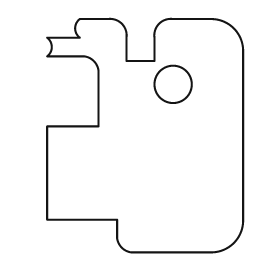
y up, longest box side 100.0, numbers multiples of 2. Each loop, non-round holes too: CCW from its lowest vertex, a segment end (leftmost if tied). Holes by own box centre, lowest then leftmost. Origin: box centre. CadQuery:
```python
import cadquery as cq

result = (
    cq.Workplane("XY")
    .moveTo(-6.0, -50.0)
    .lineTo(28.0, -50.0)
    .threePointArc((38.0, -46.0), (42.0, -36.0))
    .lineTo(42.0, 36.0)
    .threePointArc((38.0, 46.0), (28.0, 50.0))
    .lineTo(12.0, 50.0)
    .threePointArc((6.0, 48.0), (4.0, 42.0))
    .lineTo(4.0, 32.0)
    .lineTo(-8.0, 32.0)
    .lineTo(-8.0, 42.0)
    .threePointArc((-10.0, 48.0), (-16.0, 50.0))
    .lineTo(-28.0, 50.0)
    .threePointArc((-30.0, 46.0), (-28.0, 42.0))
    .lineTo(-42.0, 42.0)
    .threePointArc((-40.0, 38.0), (-42.0, 34.0))
    .lineTo(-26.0, 34.0)
    .threePointArc((-22.0, 32.0), (-20.0, 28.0))
    .lineTo(-20.0, 4.0)
    .lineTo(-42.0, 4.0)
    .lineTo(-42.0, -36.0)
    .lineTo(-12.0, -36.0)
    .lineTo(-12.0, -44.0)
    .threePointArc((-10.0, -48.0), (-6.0, -50.0))
    .close()
    .moveTo(12.0, 22.0)
    .circle(8.0)
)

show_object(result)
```